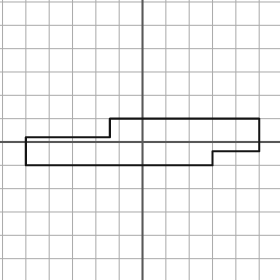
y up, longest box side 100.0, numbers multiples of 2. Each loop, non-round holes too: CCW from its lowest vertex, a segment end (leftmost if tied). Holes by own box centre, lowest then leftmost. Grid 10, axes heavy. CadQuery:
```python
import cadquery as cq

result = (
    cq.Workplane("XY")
    .moveTo(-50.0, -10.0)
    .lineTo(30.0, -10.0)
    .lineTo(30.0, -4.0)
    .lineTo(50.0, -4.0)
    .lineTo(50.0, 10.0)
    .lineTo(-14.0, 10.0)
    .lineTo(-14.0, 2.0)
    .lineTo(-50.0, 2.0)
    .close()
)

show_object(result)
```